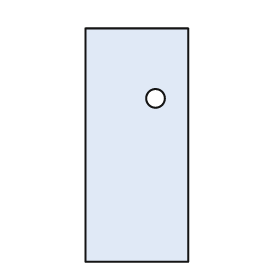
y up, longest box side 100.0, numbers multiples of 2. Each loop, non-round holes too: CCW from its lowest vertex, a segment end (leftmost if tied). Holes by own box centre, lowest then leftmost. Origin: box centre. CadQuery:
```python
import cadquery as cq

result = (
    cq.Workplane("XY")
    .moveTo(-22.0, -50.0)
    .lineTo(22.0, -50.0)
    .lineTo(22.0, 50.0)
    .lineTo(-22.0, 50.0)
    .close()
    .moveTo(8.0, 20.0)
    .circle(4.0)
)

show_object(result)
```